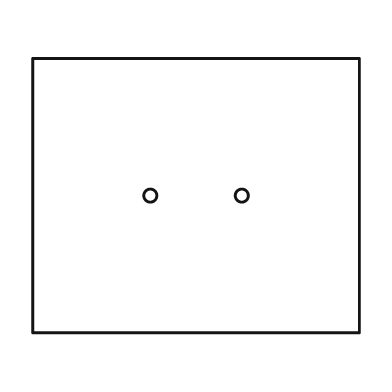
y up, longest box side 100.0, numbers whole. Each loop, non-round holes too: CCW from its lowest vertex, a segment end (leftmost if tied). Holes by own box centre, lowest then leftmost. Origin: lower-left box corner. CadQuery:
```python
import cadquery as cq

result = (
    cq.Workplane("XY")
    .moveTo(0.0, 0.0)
    .lineTo(100.0, 0.0)
    .lineTo(100.0, 84.0)
    .lineTo(0.0, 84.0)
    .close()
    .moveTo(36.0, 42.0)
    .circle(2.0)
    .moveTo(64.0, 42.0)
    .circle(2.0)
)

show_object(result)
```